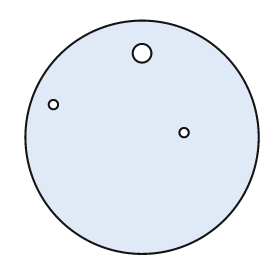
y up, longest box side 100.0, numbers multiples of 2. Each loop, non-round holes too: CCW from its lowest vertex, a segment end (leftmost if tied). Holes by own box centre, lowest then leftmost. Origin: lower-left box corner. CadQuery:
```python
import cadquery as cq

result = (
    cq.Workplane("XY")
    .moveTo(50.0, 50.0)
    .circle(50.0)
    .moveTo(68.0, 52.0)
    .circle(2.0)
    .moveTo(12.0, 64.0)
    .circle(2.0)
    .moveTo(50.0, 86.0)
    .circle(4.0)
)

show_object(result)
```